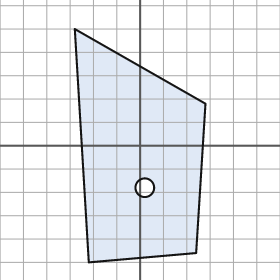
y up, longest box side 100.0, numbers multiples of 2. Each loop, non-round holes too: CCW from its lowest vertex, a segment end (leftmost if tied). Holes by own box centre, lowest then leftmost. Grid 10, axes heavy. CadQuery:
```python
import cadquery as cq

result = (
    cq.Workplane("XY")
    .moveTo(-22.0, -50.0)
    .lineTo(24.0, -46.0)
    .lineTo(28.0, 18.0)
    .lineTo(-28.0, 50.0)
    .close()
    .moveTo(2.0, -18.0)
    .circle(4.0)
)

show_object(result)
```